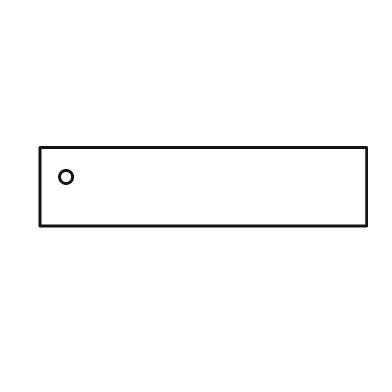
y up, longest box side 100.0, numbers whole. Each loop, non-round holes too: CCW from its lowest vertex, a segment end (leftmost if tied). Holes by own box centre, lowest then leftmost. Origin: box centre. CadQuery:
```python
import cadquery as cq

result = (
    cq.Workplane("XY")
    .moveTo(-50.0, -12.0)
    .lineTo(50.0, -12.0)
    .lineTo(50.0, 12.0)
    .lineTo(-50.0, 12.0)
    .close()
    .moveTo(-42.0, 3.0)
    .circle(2.0)
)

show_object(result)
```